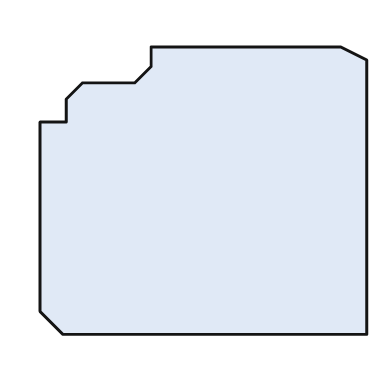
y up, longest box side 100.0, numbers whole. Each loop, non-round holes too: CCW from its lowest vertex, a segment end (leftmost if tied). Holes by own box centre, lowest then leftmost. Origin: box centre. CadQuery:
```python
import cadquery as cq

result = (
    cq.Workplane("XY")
    .moveTo(-43.0, -44.0)
    .lineTo(50.0, -44.0)
    .lineTo(50.0, 40.0)
    .lineTo(42.0, 44.0)
    .lineTo(-16.0, 44.0)
    .lineTo(-16.0, 38.0)
    .lineTo(-21.0, 33.0)
    .lineTo(-37.0, 33.0)
    .lineTo(-42.0, 28.0)
    .lineTo(-42.0, 21.0)
    .lineTo(-50.0, 21.0)
    .lineTo(-50.0, -37.0)
    .close()
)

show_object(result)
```